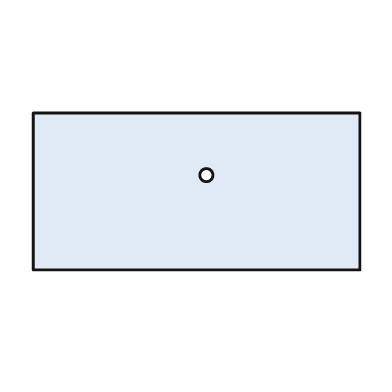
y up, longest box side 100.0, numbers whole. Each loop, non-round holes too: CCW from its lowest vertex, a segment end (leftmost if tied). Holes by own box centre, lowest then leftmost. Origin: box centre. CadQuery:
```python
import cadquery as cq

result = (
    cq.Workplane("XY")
    .moveTo(-50.0, -24.0)
    .lineTo(50.0, -24.0)
    .lineTo(50.0, 24.0)
    .lineTo(-50.0, 24.0)
    .close()
    .moveTo(3.0, 5.0)
    .circle(2.0)
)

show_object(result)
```